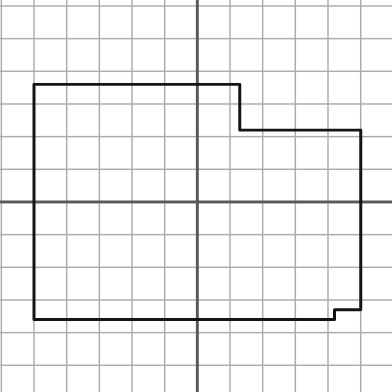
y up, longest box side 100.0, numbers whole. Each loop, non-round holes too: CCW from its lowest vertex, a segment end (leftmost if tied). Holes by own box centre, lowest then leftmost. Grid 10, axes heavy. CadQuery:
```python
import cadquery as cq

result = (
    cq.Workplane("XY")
    .moveTo(-50.0, -36.0)
    .lineTo(42.0, -36.0)
    .lineTo(42.0, -33.0)
    .lineTo(50.0, -33.0)
    .lineTo(50.0, 22.0)
    .lineTo(13.0, 22.0)
    .lineTo(13.0, 36.0)
    .lineTo(-50.0, 36.0)
    .close()
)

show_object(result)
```